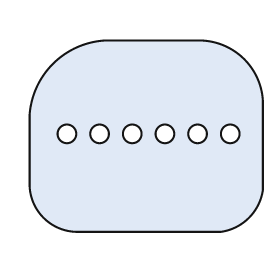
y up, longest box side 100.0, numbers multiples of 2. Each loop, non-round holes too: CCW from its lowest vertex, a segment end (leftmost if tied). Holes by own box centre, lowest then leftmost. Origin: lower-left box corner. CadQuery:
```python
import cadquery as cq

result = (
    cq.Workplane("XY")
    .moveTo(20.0, 0.0)
    .lineTo(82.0, 0.0)
    .threePointArc((94.0, 6.0), (100.0, 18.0))
    .lineTo(100.0, 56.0)
    .threePointArc((92.0, 74.0), (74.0, 82.0))
    .lineTo(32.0, 82.0)
    .threePointArc((10.0, 72.0), (0.0, 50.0))
    .lineTo(0.0, 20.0)
    .threePointArc((6.0, 6.0), (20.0, 0.0))
    .close()
    .moveTo(16.0, 42.0)
    .circle(4.0)
    .moveTo(30.0, 42.0)
    .circle(4.0)
    .moveTo(44.0, 42.0)
    .circle(4.0)
    .moveTo(58.0, 42.0)
    .circle(4.0)
    .moveTo(72.0, 42.0)
    .circle(4.0)
    .moveTo(86.0, 42.0)
    .circle(4.0)
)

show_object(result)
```